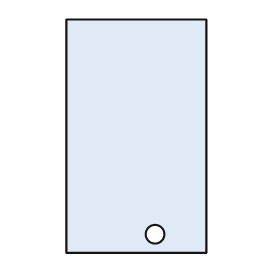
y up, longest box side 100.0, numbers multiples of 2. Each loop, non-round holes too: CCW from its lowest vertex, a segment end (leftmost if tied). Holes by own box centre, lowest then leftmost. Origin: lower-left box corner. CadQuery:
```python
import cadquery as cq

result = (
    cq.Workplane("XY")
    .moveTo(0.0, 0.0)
    .lineTo(60.0, 0.0)
    .lineTo(60.0, 100.0)
    .lineTo(0.0, 100.0)
    .close()
    .moveTo(38.0, 8.0)
    .circle(4.0)
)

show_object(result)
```